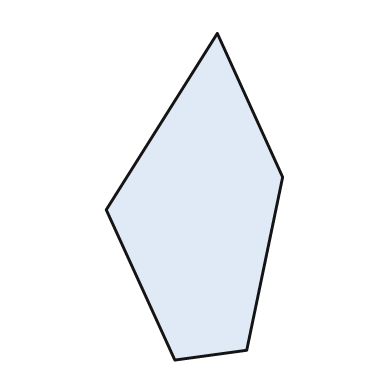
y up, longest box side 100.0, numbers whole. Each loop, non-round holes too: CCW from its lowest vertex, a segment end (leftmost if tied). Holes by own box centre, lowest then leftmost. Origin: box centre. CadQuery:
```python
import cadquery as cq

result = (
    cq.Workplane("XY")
    .moveTo(-6.0, -50.0)
    .lineTo(16.0, -47.0)
    .lineTo(27.0, 6.0)
    .lineTo(7.0, 50.0)
    .lineTo(-27.0, -4.0)
    .close()
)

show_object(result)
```